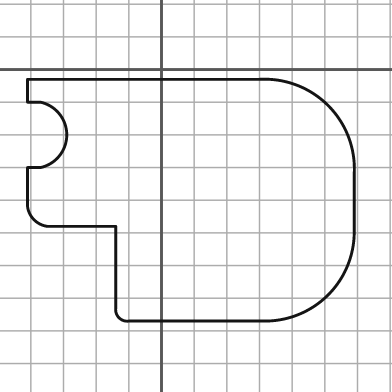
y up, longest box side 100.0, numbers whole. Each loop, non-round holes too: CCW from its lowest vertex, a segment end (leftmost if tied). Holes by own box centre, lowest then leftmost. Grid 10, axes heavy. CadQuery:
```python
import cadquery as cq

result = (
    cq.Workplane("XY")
    .moveTo(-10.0, -77.0)
    .lineTo(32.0, -77.0)
    .threePointArc((51.0, -69.0), (59.0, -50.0))
    .lineTo(59.0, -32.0)
    .threePointArc((51.0, -11.0), (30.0, -3.0))
    .lineTo(-41.0, -3.0)
    .lineTo(-41.0, -10.0)
    .lineTo(-37.0, -10.0)
    .threePointArc((-29.0, -20.0), (-37.0, -30.0))
    .lineTo(-41.0, -30.0)
    .lineTo(-41.0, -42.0)
    .threePointArc((-39.0, -46.0), (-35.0, -48.0))
    .lineTo(-14.0, -48.0)
    .lineTo(-14.0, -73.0)
    .threePointArc((-13.0, -76.0), (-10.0, -77.0))
    .close()
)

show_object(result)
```